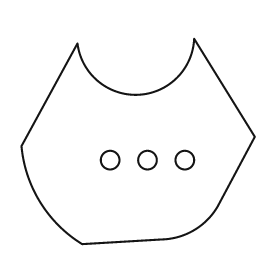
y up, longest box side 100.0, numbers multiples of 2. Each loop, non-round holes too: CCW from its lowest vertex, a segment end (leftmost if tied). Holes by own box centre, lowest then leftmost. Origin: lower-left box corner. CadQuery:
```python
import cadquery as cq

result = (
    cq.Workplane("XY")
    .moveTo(26.0, 0.0)
    .lineTo(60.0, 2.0)
    .threePointArc((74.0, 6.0), (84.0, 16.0))
    .lineTo(100.0, 46.0)
    .lineTo(74.0, 88.0)
    .threePointArc((50.0, 64.0), (24.0, 86.0))
    .lineTo(0.0, 42.0)
    .threePointArc((8.0, 18.0), (26.0, 0.0))
    .close()
    .moveTo(38.0, 36.0)
    .circle(4.0)
    .moveTo(54.0, 36.0)
    .circle(4.0)
    .moveTo(70.0, 36.0)
    .circle(4.0)
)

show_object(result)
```